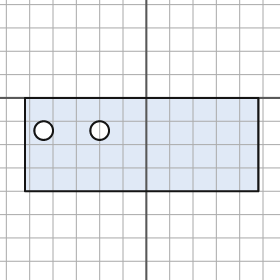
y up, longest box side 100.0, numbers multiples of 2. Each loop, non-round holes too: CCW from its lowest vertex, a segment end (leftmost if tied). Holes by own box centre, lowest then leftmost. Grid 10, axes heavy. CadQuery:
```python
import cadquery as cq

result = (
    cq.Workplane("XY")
    .moveTo(-52.0, -40.0)
    .lineTo(48.0, -40.0)
    .lineTo(48.0, 0.0)
    .lineTo(-52.0, 0.0)
    .close()
    .moveTo(-44.0, -14.0)
    .circle(4.0)
    .moveTo(-20.0, -14.0)
    .circle(4.0)
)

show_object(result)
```